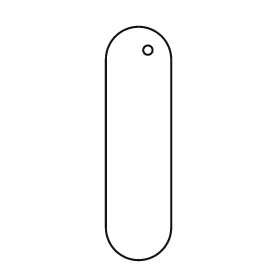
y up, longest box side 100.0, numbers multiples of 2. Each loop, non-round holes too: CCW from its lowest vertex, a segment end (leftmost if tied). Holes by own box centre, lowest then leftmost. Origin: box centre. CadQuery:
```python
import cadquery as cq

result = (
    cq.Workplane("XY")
    .moveTo(-14.0, -36.0)
    .threePointArc((0.0, -50.0), (14.0, -36.0))
    .lineTo(14.0, 36.0)
    .threePointArc((0.0, 50.0), (-14.0, 36.0))
    .close()
    .moveTo(4.0, 40.0)
    .circle(2.0)
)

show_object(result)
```